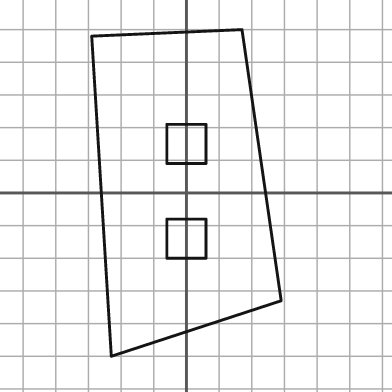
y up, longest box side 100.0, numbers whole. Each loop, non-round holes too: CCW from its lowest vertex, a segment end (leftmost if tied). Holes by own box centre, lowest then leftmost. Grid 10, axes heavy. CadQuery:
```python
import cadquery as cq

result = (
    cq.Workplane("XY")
    .moveTo(-23.0, -50.0)
    .lineTo(29.0, -33.0)
    .lineTo(17.0, 50.0)
    .lineTo(-29.0, 48.0)
    .close()
    .moveTo(-6.0, -20.0)
    .lineTo(6.0, -20.0)
    .lineTo(6.0, -8.0)
    .lineTo(-6.0, -8.0)
    .close()
    .moveTo(-6.0, 9.0)
    .lineTo(6.0, 9.0)
    .lineTo(6.0, 21.0)
    .lineTo(-6.0, 21.0)
    .close()
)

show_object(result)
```